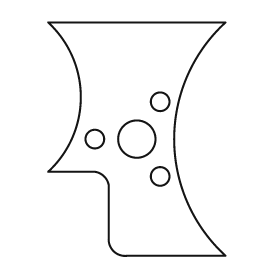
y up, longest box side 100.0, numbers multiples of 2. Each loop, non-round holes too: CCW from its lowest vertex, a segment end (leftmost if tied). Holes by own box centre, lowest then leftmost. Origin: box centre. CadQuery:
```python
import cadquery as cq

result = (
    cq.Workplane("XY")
    .moveTo(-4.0, -50.0)
    .lineTo(38.0, -50.0)
    .threePointArc((16.0, 0.0), (38.0, 50.0))
    .lineTo(-38.0, 50.0)
    .threePointArc((-24.0, 18.0), (-38.0, -14.0))
    .lineTo(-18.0, -14.0)
    .threePointArc((-14.0, -16.0), (-12.0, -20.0))
    .lineTo(-12.0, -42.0)
    .threePointArc((-10.0, -48.0), (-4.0, -50.0))
    .close()
    .moveTo(10.0, -16.0)
    .circle(4.0)
    .moveTo(-18.0, 0.0)
    .circle(4.0)
    .moveTo(0.0, 0.0)
    .circle(8.0)
    .moveTo(10.0, 16.0)
    .circle(4.0)
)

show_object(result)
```